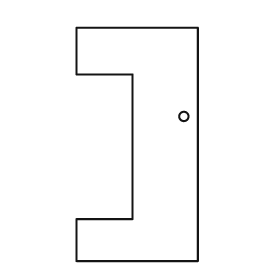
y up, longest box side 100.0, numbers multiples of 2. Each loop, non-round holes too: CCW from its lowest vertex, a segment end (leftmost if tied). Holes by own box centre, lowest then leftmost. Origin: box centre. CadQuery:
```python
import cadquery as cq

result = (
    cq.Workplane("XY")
    .moveTo(-26.0, -50.0)
    .lineTo(26.0, -50.0)
    .lineTo(26.0, 50.0)
    .lineTo(-26.0, 50.0)
    .lineTo(-26.0, 30.0)
    .lineTo(-2.0, 30.0)
    .lineTo(-2.0, -32.0)
    .lineTo(-26.0, -32.0)
    .close()
    .moveTo(20.0, 12.0)
    .circle(2.0)
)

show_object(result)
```